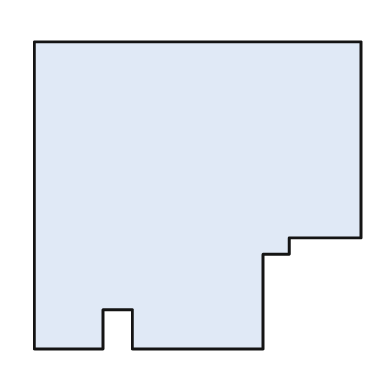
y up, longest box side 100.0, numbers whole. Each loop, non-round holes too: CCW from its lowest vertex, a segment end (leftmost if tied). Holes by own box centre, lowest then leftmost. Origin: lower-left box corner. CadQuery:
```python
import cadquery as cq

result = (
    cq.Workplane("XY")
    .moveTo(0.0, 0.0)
    .lineTo(21.0, 0.0)
    .lineTo(21.0, 12.0)
    .lineTo(30.0, 12.0)
    .lineTo(30.0, 0.0)
    .lineTo(70.0, 0.0)
    .lineTo(70.0, 29.0)
    .lineTo(78.0, 29.0)
    .lineTo(78.0, 34.0)
    .lineTo(100.0, 34.0)
    .lineTo(100.0, 94.0)
    .lineTo(0.0, 94.0)
    .close()
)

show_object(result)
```